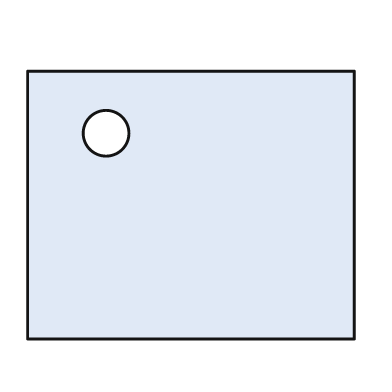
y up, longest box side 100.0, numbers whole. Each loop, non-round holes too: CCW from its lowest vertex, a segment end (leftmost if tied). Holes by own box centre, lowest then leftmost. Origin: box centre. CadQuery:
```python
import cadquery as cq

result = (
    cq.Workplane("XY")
    .moveTo(-50.0, -41.0)
    .lineTo(50.0, -41.0)
    .lineTo(50.0, 41.0)
    .lineTo(-50.0, 41.0)
    .close()
    .moveTo(-26.0, 22.0)
    .circle(7.0)
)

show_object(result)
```